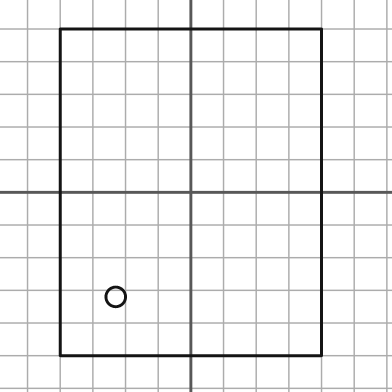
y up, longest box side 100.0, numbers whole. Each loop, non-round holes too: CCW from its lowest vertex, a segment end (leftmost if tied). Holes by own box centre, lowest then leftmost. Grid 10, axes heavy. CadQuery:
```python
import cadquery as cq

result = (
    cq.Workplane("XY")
    .moveTo(-40.0, -50.0)
    .lineTo(40.0, -50.0)
    .lineTo(40.0, 50.0)
    .lineTo(-40.0, 50.0)
    .close()
    .moveTo(-23.0, -32.0)
    .circle(3.0)
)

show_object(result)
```